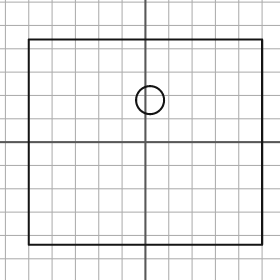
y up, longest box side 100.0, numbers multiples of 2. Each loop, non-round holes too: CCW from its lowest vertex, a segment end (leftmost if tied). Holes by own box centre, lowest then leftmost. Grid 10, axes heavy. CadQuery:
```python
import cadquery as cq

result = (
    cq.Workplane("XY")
    .moveTo(-50.0, -44.0)
    .lineTo(50.0, -44.0)
    .lineTo(50.0, 44.0)
    .lineTo(-50.0, 44.0)
    .close()
    .moveTo(2.0, 18.0)
    .circle(6.0)
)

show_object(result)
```